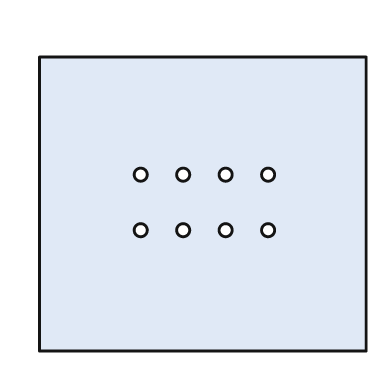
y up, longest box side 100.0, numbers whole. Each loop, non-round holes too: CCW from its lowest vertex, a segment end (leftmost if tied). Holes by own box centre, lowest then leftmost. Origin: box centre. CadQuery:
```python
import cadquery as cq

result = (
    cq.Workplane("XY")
    .moveTo(-50.0, -45.0)
    .lineTo(50.0, -45.0)
    .lineTo(50.0, 45.0)
    .lineTo(-50.0, 45.0)
    .close()
    .moveTo(-19.0, -8.0)
    .circle(2.0)
    .moveTo(-6.0, -8.0)
    .circle(2.0)
    .moveTo(7.0, -8.0)
    .circle(2.0)
    .moveTo(20.0, -8.0)
    .circle(2.0)
    .moveTo(-19.0, 9.0)
    .circle(2.0)
    .moveTo(-6.0, 9.0)
    .circle(2.0)
    .moveTo(7.0, 9.0)
    .circle(2.0)
    .moveTo(20.0, 9.0)
    .circle(2.0)
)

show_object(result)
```